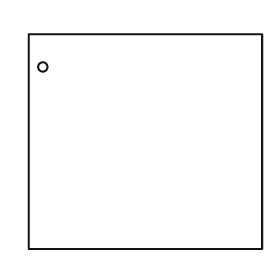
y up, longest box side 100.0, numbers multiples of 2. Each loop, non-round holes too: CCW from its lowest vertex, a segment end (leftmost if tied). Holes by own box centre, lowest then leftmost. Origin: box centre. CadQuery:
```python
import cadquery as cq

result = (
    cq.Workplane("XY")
    .moveTo(-50.0, -46.0)
    .lineTo(50.0, -46.0)
    .lineTo(50.0, 46.0)
    .lineTo(-50.0, 46.0)
    .close()
    .moveTo(-44.0, 32.0)
    .circle(2.0)
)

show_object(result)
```